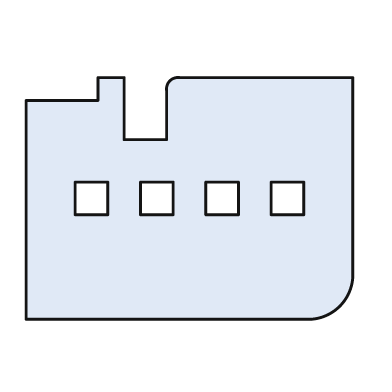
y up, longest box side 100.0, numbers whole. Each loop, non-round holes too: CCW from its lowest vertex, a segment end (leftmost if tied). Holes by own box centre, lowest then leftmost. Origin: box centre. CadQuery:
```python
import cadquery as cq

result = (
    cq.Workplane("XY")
    .moveTo(-50.0, -37.0)
    .lineTo(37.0, -37.0)
    .threePointArc((46.0, -33.0), (50.0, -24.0))
    .lineTo(50.0, 37.0)
    .lineTo(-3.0, 37.0)
    .threePointArc((-6.0, 36.0), (-7.0, 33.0))
    .lineTo(-7.0, 18.0)
    .lineTo(-20.0, 18.0)
    .lineTo(-20.0, 37.0)
    .lineTo(-28.0, 37.0)
    .lineTo(-28.0, 30.0)
    .lineTo(-50.0, 30.0)
    .close()
    .moveTo(-35.0, -5.0)
    .lineTo(-25.0, -5.0)
    .lineTo(-25.0, 5.0)
    .lineTo(-35.0, 5.0)
    .close()
    .moveTo(-15.0, -5.0)
    .lineTo(-5.0, -5.0)
    .lineTo(-5.0, 5.0)
    .lineTo(-15.0, 5.0)
    .close()
    .moveTo(5.0, -5.0)
    .lineTo(15.0, -5.0)
    .lineTo(15.0, 5.0)
    .lineTo(5.0, 5.0)
    .close()
    .moveTo(25.0, -5.0)
    .lineTo(35.0, -5.0)
    .lineTo(35.0, 5.0)
    .lineTo(25.0, 5.0)
    .close()
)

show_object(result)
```